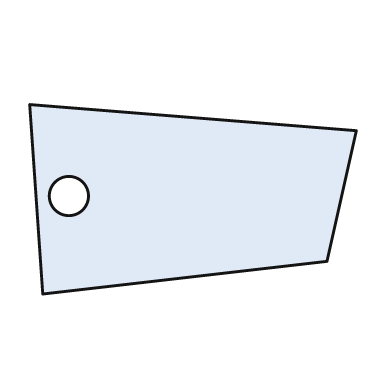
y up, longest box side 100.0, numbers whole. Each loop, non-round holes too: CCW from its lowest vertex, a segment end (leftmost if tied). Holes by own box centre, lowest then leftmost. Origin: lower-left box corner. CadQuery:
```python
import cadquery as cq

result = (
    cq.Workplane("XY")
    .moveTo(4.0, 0.0)
    .lineTo(91.0, 10.0)
    .lineTo(100.0, 50.0)
    .lineTo(0.0, 58.0)
    .close()
    .moveTo(12.0, 30.0)
    .circle(6.0)
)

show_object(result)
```